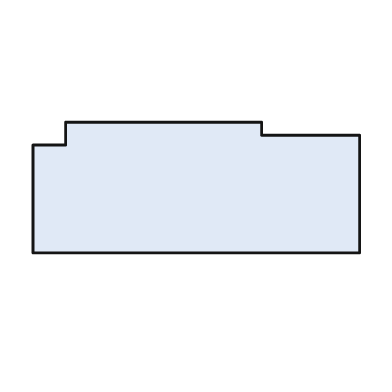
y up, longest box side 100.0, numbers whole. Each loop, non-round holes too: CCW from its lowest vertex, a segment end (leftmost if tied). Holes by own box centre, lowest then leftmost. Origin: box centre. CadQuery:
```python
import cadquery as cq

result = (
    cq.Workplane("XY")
    .moveTo(-50.0, -20.0)
    .lineTo(50.0, -20.0)
    .lineTo(50.0, 16.0)
    .lineTo(20.0, 16.0)
    .lineTo(20.0, 20.0)
    .lineTo(-40.0, 20.0)
    .lineTo(-40.0, 13.0)
    .lineTo(-50.0, 13.0)
    .close()
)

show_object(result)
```